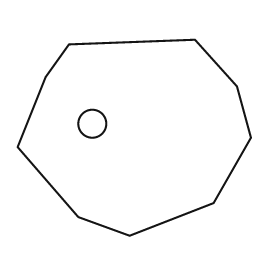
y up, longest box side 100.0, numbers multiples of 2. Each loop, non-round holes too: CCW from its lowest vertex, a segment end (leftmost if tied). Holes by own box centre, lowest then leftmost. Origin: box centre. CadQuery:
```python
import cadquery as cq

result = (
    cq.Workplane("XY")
    .moveTo(-2.0, -42.0)
    .lineTo(34.0, -28.0)
    .lineTo(50.0, 0.0)
    .lineTo(44.0, 22.0)
    .lineTo(26.0, 42.0)
    .lineTo(-28.0, 40.0)
    .lineTo(-38.0, 26.0)
    .lineTo(-50.0, -4.0)
    .lineTo(-24.0, -34.0)
    .close()
    .moveTo(-18.0, 6.0)
    .circle(6.0)
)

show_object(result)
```